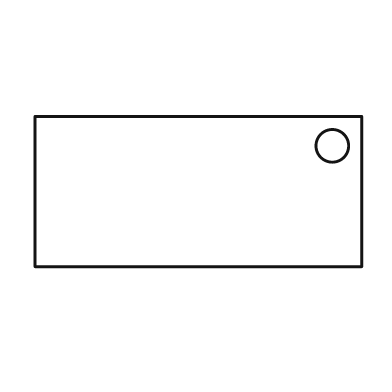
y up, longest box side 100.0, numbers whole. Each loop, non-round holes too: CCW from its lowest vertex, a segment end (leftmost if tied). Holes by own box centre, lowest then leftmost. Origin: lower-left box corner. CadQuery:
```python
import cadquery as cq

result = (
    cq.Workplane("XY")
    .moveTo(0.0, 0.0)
    .lineTo(100.0, 0.0)
    .lineTo(100.0, 46.0)
    .lineTo(0.0, 46.0)
    .close()
    .moveTo(91.0, 37.0)
    .circle(5.0)
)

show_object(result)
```